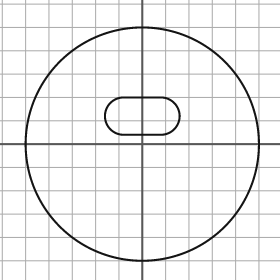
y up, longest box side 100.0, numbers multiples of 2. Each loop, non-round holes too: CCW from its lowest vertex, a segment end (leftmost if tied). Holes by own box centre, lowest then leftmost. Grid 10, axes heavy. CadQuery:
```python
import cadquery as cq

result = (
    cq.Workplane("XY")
    .moveTo(0.0, 0.0)
    .circle(50.0)
    .moveTo(-8.0, 4.0)
    .lineTo(8.0, 4.0)
    .threePointArc((16.0, 12.0), (8.0, 20.0))
    .lineTo(-8.0, 20.0)
    .threePointArc((-16.0, 12.0), (-8.0, 4.0))
    .close()
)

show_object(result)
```